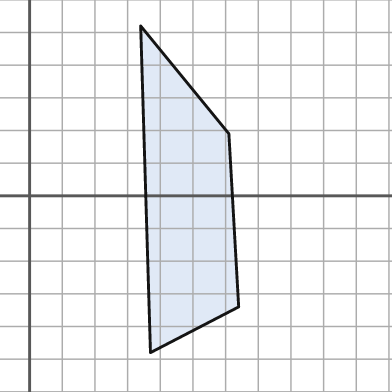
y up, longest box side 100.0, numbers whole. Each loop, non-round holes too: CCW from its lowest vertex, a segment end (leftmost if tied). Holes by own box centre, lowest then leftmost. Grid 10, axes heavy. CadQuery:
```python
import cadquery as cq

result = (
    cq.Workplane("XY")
    .moveTo(37.0, -48.0)
    .lineTo(64.0, -34.0)
    .lineTo(61.0, 19.0)
    .lineTo(34.0, 52.0)
    .close()
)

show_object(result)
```